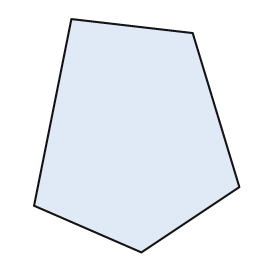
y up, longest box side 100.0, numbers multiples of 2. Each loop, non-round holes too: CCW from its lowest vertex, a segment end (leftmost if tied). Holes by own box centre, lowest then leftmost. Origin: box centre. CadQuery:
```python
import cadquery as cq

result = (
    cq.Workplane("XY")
    .moveTo(2.0, -50.0)
    .lineTo(44.0, -22.0)
    .lineTo(24.0, 44.0)
    .lineTo(-28.0, 50.0)
    .lineTo(-44.0, -30.0)
    .close()
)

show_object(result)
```